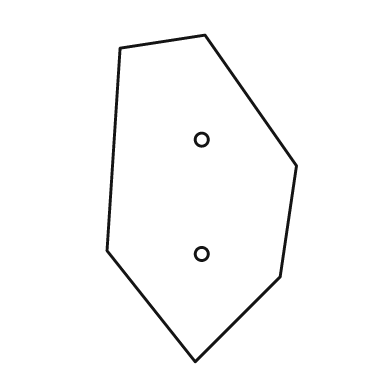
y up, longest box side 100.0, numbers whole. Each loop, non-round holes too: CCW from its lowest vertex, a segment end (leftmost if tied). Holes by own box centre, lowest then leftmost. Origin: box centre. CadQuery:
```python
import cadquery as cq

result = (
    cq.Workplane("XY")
    .moveTo(-2.0, -50.0)
    .lineTo(24.0, -24.0)
    .lineTo(29.0, 10.0)
    .lineTo(1.0, 50.0)
    .lineTo(-25.0, 46.0)
    .lineTo(-29.0, -16.0)
    .close()
    .moveTo(0.0, -17.0)
    .circle(2.0)
    .moveTo(0.0, 18.0)
    .circle(2.0)
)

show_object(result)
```